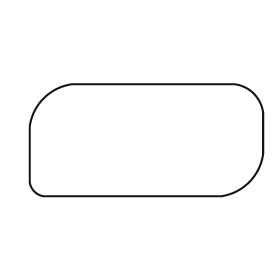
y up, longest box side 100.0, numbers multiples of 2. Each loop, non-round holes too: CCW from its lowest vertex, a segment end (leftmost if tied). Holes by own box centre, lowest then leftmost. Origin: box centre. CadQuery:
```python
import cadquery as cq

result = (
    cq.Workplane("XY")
    .moveTo(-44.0, -24.0)
    .lineTo(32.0, -24.0)
    .threePointArc((44.0, -18.0), (50.0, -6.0))
    .lineTo(50.0, 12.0)
    .threePointArc((46.0, 20.0), (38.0, 24.0))
    .lineTo(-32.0, 24.0)
    .threePointArc((-44.0, 18.0), (-50.0, 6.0))
    .lineTo(-50.0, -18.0)
    .threePointArc((-48.0, -22.0), (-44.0, -24.0))
    .close()
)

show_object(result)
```